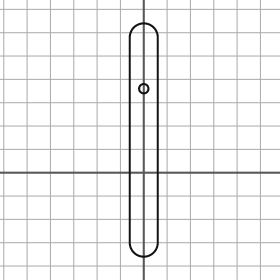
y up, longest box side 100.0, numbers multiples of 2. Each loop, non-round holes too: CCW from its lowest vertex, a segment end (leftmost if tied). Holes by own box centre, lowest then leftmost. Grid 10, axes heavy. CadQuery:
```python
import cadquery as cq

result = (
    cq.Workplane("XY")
    .moveTo(-6.0, -30.0)
    .threePointArc((0.0, -36.0), (6.0, -30.0))
    .lineTo(6.0, 58.0)
    .threePointArc((0.0, 64.0), (-6.0, 58.0))
    .close()
    .moveTo(0.0, 36.0)
    .circle(2.0)
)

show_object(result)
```